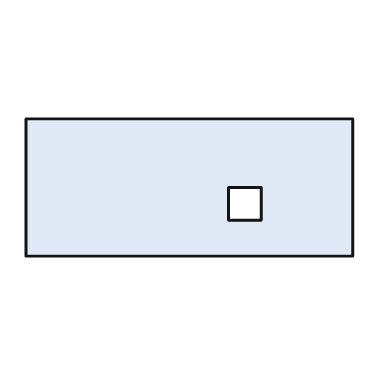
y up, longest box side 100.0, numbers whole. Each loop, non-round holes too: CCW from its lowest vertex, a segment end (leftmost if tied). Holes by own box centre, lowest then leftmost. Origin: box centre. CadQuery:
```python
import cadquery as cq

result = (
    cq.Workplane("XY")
    .moveTo(-50.0, -21.0)
    .lineTo(50.0, -21.0)
    .lineTo(50.0, 21.0)
    .lineTo(-50.0, 21.0)
    .close()
    .moveTo(12.0, -10.0)
    .lineTo(22.0, -10.0)
    .lineTo(22.0, 0.0)
    .lineTo(12.0, 0.0)
    .close()
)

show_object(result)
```